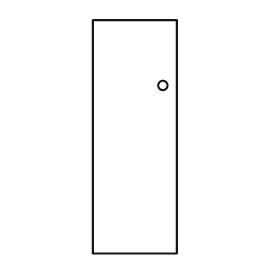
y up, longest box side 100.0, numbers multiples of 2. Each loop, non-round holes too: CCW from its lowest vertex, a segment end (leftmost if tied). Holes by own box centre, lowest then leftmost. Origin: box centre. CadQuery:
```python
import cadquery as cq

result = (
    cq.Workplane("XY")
    .moveTo(-18.0, -50.0)
    .lineTo(18.0, -50.0)
    .lineTo(18.0, 50.0)
    .lineTo(-18.0, 50.0)
    .close()
    .moveTo(12.0, 22.0)
    .circle(2.0)
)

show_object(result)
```